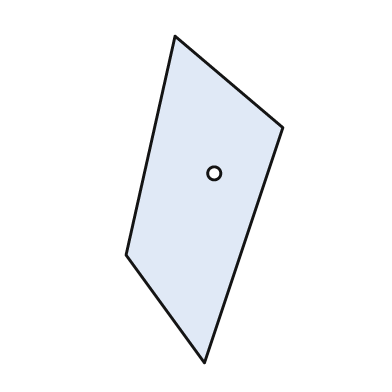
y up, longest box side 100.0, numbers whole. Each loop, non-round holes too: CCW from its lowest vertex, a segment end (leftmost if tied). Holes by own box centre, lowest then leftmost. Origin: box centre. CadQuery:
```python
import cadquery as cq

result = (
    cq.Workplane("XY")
    .moveTo(0.0, -50.0)
    .lineTo(24.0, 22.0)
    .lineTo(-9.0, 50.0)
    .lineTo(-24.0, -17.0)
    .close()
    .moveTo(3.0, 8.0)
    .circle(2.0)
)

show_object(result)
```